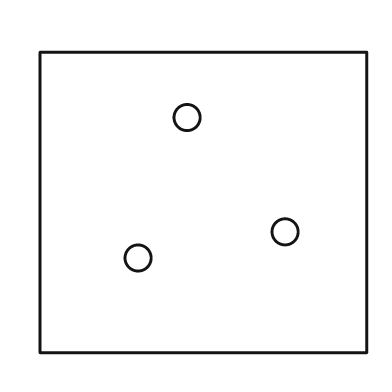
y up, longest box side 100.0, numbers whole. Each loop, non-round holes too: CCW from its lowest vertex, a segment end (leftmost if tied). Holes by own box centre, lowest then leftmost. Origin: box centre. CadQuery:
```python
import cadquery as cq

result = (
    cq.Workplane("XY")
    .moveTo(-50.0, -46.0)
    .lineTo(50.0, -46.0)
    .lineTo(50.0, 46.0)
    .lineTo(-50.0, 46.0)
    .close()
    .moveTo(-20.0, -17.0)
    .circle(4.0)
    .moveTo(25.0, -9.0)
    .circle(4.0)
    .moveTo(-5.0, 26.0)
    .circle(4.0)
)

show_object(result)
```